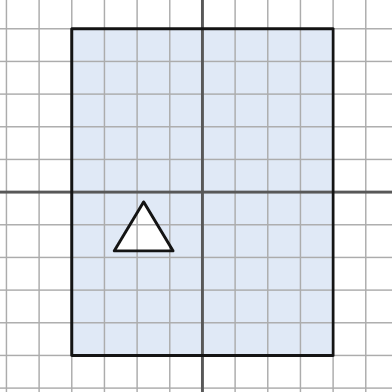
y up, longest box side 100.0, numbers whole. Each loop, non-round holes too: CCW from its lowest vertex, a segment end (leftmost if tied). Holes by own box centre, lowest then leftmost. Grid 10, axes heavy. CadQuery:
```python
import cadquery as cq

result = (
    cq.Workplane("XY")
    .moveTo(-40.0, -50.0)
    .lineTo(40.0, -50.0)
    .lineTo(40.0, 50.0)
    .lineTo(-40.0, 50.0)
    .close()
    .moveTo(-27.0, -18.0)
    .lineTo(-9.0, -18.0)
    .lineTo(-18.0, -3.0)
    .close()
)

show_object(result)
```